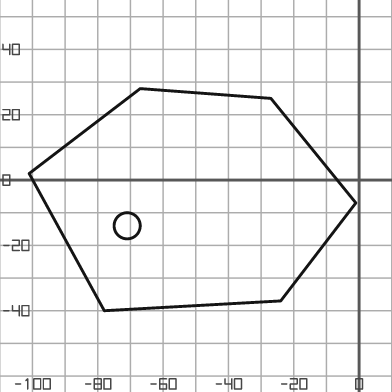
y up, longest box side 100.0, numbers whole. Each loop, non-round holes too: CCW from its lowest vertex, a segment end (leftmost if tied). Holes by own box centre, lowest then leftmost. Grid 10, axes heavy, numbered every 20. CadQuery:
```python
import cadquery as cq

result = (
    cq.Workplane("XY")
    .moveTo(-78.0, -40.0)
    .lineTo(-24.0, -37.0)
    .lineTo(-1.0, -7.0)
    .lineTo(-27.0, 25.0)
    .lineTo(-67.0, 28.0)
    .lineTo(-101.0, 2.0)
    .close()
    .moveTo(-71.0, -14.0)
    .circle(4.0)
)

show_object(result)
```